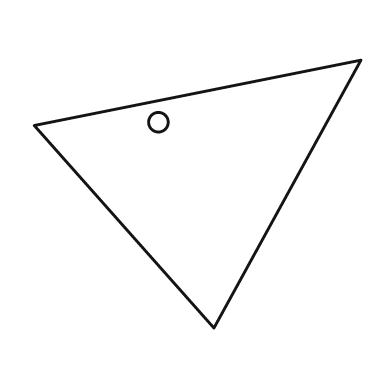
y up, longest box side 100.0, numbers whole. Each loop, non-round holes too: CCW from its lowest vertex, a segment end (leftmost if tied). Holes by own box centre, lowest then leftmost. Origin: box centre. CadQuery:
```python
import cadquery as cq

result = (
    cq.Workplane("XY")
    .moveTo(5.0, -41.0)
    .lineTo(50.0, 41.0)
    .lineTo(-50.0, 21.0)
    .close()
    .moveTo(-12.0, 22.0)
    .circle(3.0)
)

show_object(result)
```